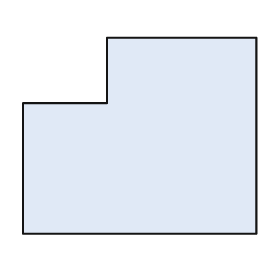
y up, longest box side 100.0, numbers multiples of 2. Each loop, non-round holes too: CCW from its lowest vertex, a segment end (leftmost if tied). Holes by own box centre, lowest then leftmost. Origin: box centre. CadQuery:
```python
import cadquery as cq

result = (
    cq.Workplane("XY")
    .moveTo(-50.0, -42.0)
    .lineTo(50.0, -42.0)
    .lineTo(50.0, 42.0)
    .lineTo(-14.0, 42.0)
    .lineTo(-14.0, 14.0)
    .lineTo(-50.0, 14.0)
    .close()
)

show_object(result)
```